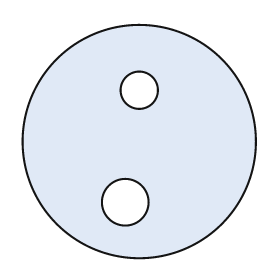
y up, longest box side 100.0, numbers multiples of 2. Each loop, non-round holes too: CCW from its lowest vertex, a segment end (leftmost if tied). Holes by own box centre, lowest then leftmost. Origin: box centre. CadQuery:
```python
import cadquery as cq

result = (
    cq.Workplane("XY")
    .moveTo(0.0, 0.0)
    .circle(50.0)
    .moveTo(-6.0, -26.0)
    .circle(10.0)
    .moveTo(0.0, 22.0)
    .circle(8.0)
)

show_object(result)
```